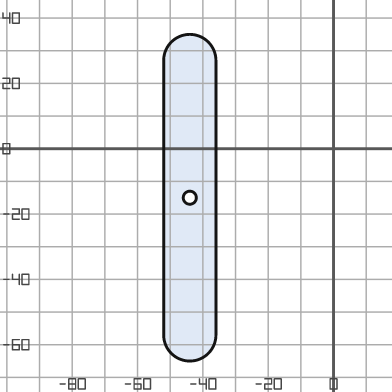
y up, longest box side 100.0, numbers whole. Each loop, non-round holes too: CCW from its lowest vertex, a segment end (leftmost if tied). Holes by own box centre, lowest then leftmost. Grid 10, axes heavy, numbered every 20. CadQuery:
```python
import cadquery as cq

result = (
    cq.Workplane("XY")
    .moveTo(-52.0, -57.0)
    .threePointArc((-44.0, -65.0), (-36.0, -57.0))
    .lineTo(-36.0, 27.0)
    .threePointArc((-44.0, 35.0), (-52.0, 27.0))
    .close()
    .moveTo(-44.0, -15.0)
    .circle(2.0)
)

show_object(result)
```